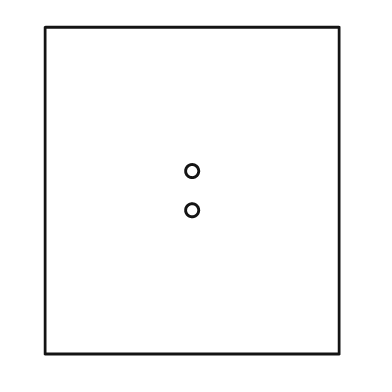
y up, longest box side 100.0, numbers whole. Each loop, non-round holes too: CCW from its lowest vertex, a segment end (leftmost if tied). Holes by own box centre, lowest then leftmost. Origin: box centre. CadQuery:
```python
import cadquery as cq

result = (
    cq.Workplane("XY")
    .moveTo(-45.0, -50.0)
    .lineTo(45.0, -50.0)
    .lineTo(45.0, 50.0)
    .lineTo(-45.0, 50.0)
    .close()
    .moveTo(0.0, -6.0)
    .circle(2.0)
    .moveTo(0.0, 6.0)
    .circle(2.0)
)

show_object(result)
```